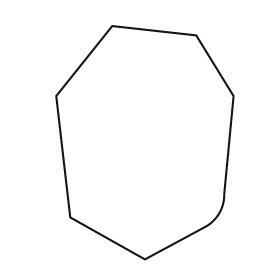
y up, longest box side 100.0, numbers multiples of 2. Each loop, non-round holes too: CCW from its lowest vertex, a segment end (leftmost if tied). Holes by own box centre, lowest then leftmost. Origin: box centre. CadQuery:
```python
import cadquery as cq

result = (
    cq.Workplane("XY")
    .moveTo(0.0, -50.0)
    .lineTo(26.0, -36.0)
    .threePointArc((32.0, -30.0), (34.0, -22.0))
    .lineTo(38.0, 20.0)
    .lineTo(22.0, 46.0)
    .lineTo(-14.0, 50.0)
    .lineTo(-38.0, 20.0)
    .lineTo(-32.0, -32.0)
    .close()
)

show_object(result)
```